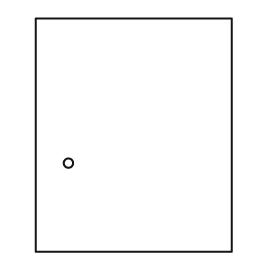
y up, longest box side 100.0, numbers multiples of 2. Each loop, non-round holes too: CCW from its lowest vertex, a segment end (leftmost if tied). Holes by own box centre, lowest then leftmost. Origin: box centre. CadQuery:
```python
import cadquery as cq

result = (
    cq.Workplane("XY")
    .moveTo(-42.0, -50.0)
    .lineTo(42.0, -50.0)
    .lineTo(42.0, 50.0)
    .lineTo(-42.0, 50.0)
    .close()
    .moveTo(-28.0, -12.0)
    .circle(2.0)
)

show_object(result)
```